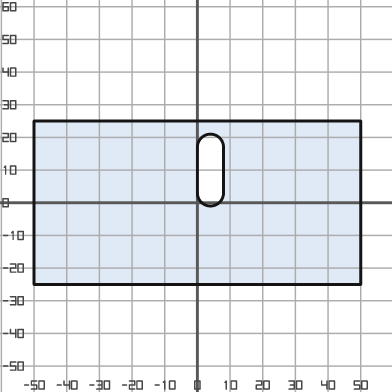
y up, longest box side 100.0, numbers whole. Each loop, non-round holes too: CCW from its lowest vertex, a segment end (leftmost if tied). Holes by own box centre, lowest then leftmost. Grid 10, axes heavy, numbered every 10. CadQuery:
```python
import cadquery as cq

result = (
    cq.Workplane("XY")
    .moveTo(-50.0, -25.0)
    .lineTo(50.0, -25.0)
    .lineTo(50.0, 25.0)
    .lineTo(-50.0, 25.0)
    .close()
    .moveTo(0.0, 3.0)
    .threePointArc((4.0, -1.0), (8.0, 3.0))
    .lineTo(8.0, 17.0)
    .threePointArc((4.0, 21.0), (0.0, 17.0))
    .close()
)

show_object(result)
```